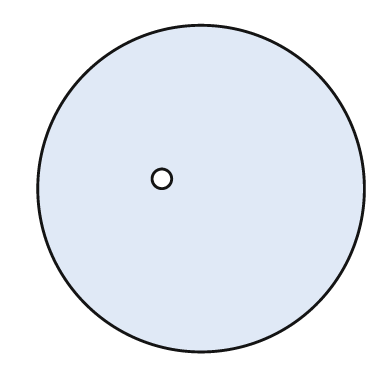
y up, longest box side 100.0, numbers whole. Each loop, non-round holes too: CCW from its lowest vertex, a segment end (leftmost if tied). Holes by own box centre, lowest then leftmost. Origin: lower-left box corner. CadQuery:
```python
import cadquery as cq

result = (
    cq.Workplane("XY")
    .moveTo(50.0, 50.0)
    .circle(50.0)
    .moveTo(38.0, 53.0)
    .circle(3.0)
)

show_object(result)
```